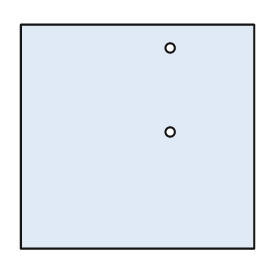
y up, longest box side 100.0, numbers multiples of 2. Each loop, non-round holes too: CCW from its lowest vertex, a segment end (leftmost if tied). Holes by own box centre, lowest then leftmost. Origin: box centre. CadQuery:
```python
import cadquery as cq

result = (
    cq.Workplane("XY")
    .moveTo(-50.0, -48.0)
    .lineTo(50.0, -48.0)
    .lineTo(50.0, 48.0)
    .lineTo(-50.0, 48.0)
    .close()
    .moveTo(14.0, 2.0)
    .circle(2.0)
    .moveTo(14.0, 38.0)
    .circle(2.0)
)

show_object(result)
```